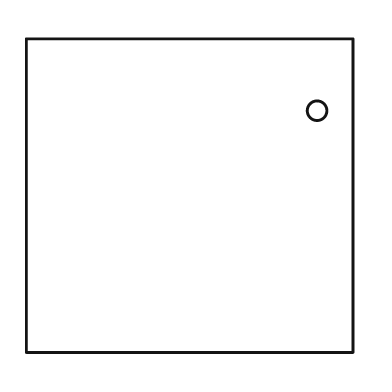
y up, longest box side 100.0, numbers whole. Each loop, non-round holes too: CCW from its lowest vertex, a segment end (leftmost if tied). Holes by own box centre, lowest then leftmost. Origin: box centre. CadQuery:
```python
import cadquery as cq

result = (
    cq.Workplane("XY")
    .moveTo(-50.0, -48.0)
    .lineTo(50.0, -48.0)
    .lineTo(50.0, 48.0)
    .lineTo(-50.0, 48.0)
    .close()
    .moveTo(39.0, 26.0)
    .circle(3.0)
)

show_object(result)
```